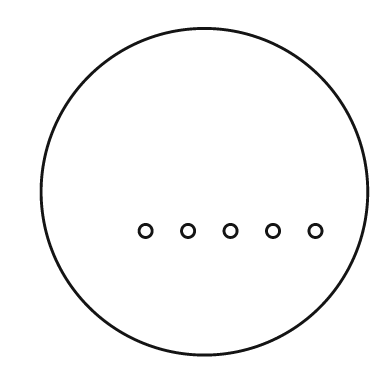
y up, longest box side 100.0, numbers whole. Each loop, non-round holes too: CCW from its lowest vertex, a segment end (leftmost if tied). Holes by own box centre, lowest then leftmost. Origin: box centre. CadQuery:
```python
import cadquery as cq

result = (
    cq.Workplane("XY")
    .moveTo(0.0, 0.0)
    .circle(50.0)
    .moveTo(-18.0, -12.0)
    .circle(2.0)
    .moveTo(-5.0, -12.0)
    .circle(2.0)
    .moveTo(8.0, -12.0)
    .circle(2.0)
    .moveTo(21.0, -12.0)
    .circle(2.0)
    .moveTo(34.0, -12.0)
    .circle(2.0)
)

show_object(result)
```